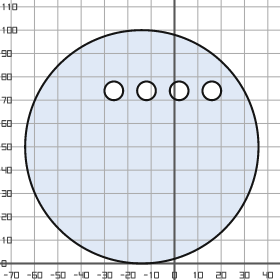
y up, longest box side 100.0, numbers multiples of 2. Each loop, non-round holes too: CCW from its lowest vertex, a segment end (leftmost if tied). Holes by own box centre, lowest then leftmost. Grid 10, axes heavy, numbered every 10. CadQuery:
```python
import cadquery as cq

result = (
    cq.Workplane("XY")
    .moveTo(-14.0, 50.0)
    .circle(50.0)
    .moveTo(-26.0, 74.0)
    .circle(4.0)
    .moveTo(-12.0, 74.0)
    .circle(4.0)
    .moveTo(2.0, 74.0)
    .circle(4.0)
    .moveTo(16.0, 74.0)
    .circle(4.0)
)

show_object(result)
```